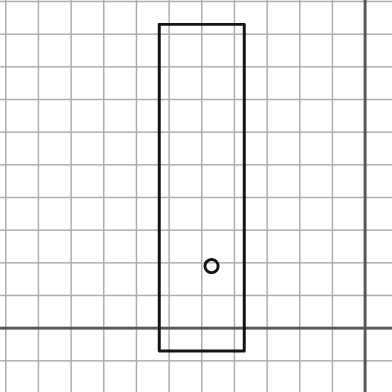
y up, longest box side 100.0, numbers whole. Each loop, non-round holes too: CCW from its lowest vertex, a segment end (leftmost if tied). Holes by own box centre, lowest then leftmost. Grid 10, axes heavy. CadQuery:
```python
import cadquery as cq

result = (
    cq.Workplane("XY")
    .moveTo(-63.0, -7.0)
    .lineTo(-37.0, -7.0)
    .lineTo(-37.0, 93.0)
    .lineTo(-63.0, 93.0)
    .close()
    .moveTo(-47.0, 19.0)
    .circle(2.0)
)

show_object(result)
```